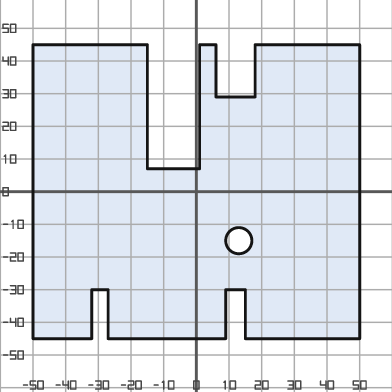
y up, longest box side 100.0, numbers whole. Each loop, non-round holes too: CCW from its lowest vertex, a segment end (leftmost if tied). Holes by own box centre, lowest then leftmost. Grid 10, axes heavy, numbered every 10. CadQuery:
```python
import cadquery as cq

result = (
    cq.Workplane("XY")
    .moveTo(-50.0, -45.0)
    .lineTo(-32.0, -45.0)
    .lineTo(-32.0, -30.0)
    .lineTo(-27.0, -30.0)
    .lineTo(-27.0, -45.0)
    .lineTo(9.0, -45.0)
    .lineTo(9.0, -30.0)
    .lineTo(15.0, -30.0)
    .lineTo(15.0, -45.0)
    .lineTo(50.0, -45.0)
    .lineTo(50.0, 45.0)
    .lineTo(18.0, 45.0)
    .lineTo(18.0, 29.0)
    .lineTo(6.0, 29.0)
    .lineTo(6.0, 45.0)
    .lineTo(1.0, 45.0)
    .lineTo(1.0, 7.0)
    .lineTo(-15.0, 7.0)
    .lineTo(-15.0, 45.0)
    .lineTo(-50.0, 45.0)
    .close()
    .moveTo(13.0, -15.0)
    .circle(4.0)
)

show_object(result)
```